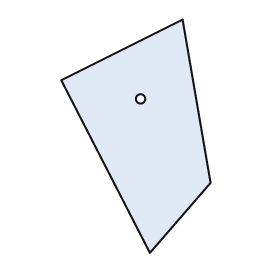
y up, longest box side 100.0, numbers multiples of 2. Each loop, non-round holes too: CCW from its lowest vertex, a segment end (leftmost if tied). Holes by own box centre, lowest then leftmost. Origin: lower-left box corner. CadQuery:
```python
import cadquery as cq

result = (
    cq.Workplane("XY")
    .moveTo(38.0, 0.0)
    .lineTo(64.0, 30.0)
    .lineTo(52.0, 100.0)
    .lineTo(0.0, 74.0)
    .close()
    .moveTo(34.0, 66.0)
    .circle(2.0)
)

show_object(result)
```